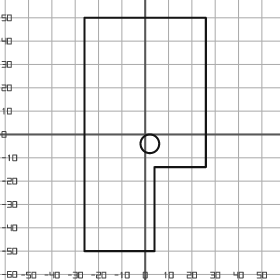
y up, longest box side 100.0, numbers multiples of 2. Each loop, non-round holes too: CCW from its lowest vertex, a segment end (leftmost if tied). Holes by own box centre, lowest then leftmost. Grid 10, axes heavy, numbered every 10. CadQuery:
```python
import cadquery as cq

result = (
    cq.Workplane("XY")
    .moveTo(-26.0, -50.0)
    .lineTo(4.0, -50.0)
    .lineTo(4.0, -14.0)
    .lineTo(26.0, -14.0)
    .lineTo(26.0, 50.0)
    .lineTo(-26.0, 50.0)
    .close()
    .moveTo(2.0, -4.0)
    .circle(4.0)
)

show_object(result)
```